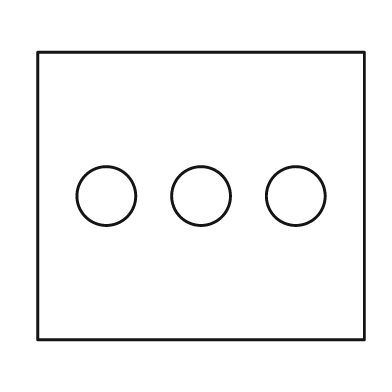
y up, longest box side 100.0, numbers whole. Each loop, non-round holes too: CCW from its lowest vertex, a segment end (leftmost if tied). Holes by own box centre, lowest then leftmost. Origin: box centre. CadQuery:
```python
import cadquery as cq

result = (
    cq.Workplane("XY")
    .moveTo(-50.0, -44.0)
    .lineTo(50.0, -44.0)
    .lineTo(50.0, 44.0)
    .lineTo(-50.0, 44.0)
    .close()
    .moveTo(-29.0, 0.0)
    .circle(9.0)
    .moveTo(0.0, 0.0)
    .circle(9.0)
    .moveTo(29.0, 0.0)
    .circle(9.0)
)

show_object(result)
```